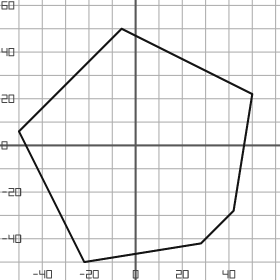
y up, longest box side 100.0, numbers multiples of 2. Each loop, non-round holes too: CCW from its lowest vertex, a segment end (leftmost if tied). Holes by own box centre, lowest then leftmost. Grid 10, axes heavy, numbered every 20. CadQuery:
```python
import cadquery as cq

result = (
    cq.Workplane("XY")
    .moveTo(-22.0, -50.0)
    .lineTo(28.0, -42.0)
    .lineTo(42.0, -28.0)
    .lineTo(50.0, 22.0)
    .lineTo(-6.0, 50.0)
    .lineTo(-50.0, 6.0)
    .close()
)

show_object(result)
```